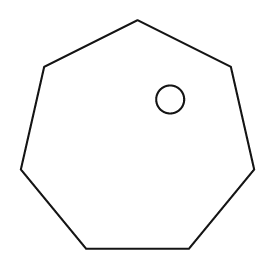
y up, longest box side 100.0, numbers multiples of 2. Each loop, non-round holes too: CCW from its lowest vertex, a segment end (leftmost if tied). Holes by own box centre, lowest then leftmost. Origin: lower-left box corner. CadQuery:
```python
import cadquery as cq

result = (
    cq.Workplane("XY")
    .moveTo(28.0, 0.0)
    .lineTo(72.0, 0.0)
    .lineTo(100.0, 34.0)
    .lineTo(90.0, 78.0)
    .lineTo(50.0, 98.0)
    .lineTo(10.0, 78.0)
    .lineTo(0.0, 34.0)
    .close()
    .moveTo(64.0, 64.0)
    .circle(6.0)
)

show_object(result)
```